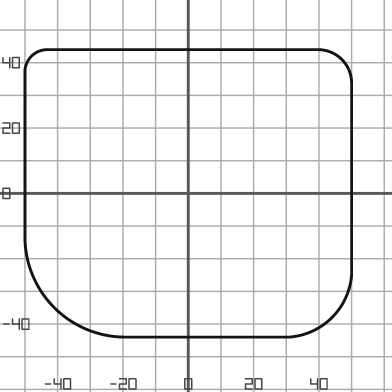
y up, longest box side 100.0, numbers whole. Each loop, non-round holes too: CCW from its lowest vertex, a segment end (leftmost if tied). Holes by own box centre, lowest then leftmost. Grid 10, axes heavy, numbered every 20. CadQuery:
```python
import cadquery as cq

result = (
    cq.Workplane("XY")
    .moveTo(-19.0, -44.0)
    .lineTo(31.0, -44.0)
    .threePointArc((44.0, -38.0), (50.0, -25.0))
    .lineTo(50.0, 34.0)
    .threePointArc((47.0, 41.0), (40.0, 44.0))
    .lineTo(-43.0, 44.0)
    .threePointArc((-48.0, 42.0), (-50.0, 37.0))
    .lineTo(-50.0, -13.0)
    .threePointArc((-41.0, -35.0), (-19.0, -44.0))
    .close()
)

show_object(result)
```